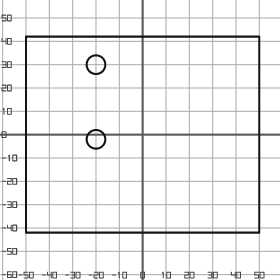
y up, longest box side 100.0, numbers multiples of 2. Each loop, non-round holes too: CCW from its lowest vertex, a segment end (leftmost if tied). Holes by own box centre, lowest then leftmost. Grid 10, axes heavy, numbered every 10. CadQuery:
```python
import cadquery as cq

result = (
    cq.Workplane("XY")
    .moveTo(-50.0, -42.0)
    .lineTo(50.0, -42.0)
    .lineTo(50.0, 42.0)
    .lineTo(-50.0, 42.0)
    .close()
    .moveTo(-20.0, -2.0)
    .circle(4.0)
    .moveTo(-20.0, 30.0)
    .circle(4.0)
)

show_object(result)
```